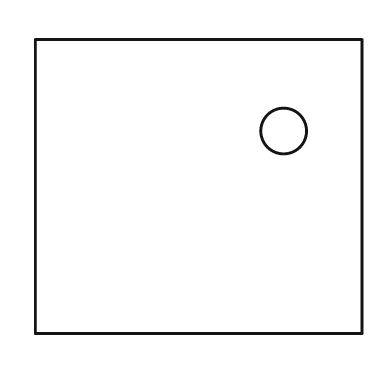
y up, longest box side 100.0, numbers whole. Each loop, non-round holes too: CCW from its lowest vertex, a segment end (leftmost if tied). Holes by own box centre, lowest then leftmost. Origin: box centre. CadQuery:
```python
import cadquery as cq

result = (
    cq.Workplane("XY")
    .moveTo(-50.0, -45.0)
    .lineTo(50.0, -45.0)
    .lineTo(50.0, 45.0)
    .lineTo(-50.0, 45.0)
    .close()
    .moveTo(26.0, 17.0)
    .circle(7.0)
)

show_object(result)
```